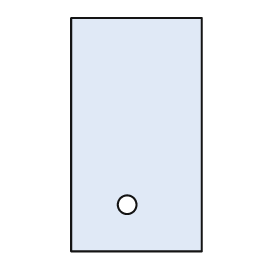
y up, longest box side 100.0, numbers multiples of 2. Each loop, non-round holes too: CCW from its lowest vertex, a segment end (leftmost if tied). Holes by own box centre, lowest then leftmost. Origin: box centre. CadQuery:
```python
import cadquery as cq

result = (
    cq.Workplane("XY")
    .moveTo(-28.0, -50.0)
    .lineTo(28.0, -50.0)
    .lineTo(28.0, 50.0)
    .lineTo(-28.0, 50.0)
    .close()
    .moveTo(-4.0, -30.0)
    .circle(4.0)
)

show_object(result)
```